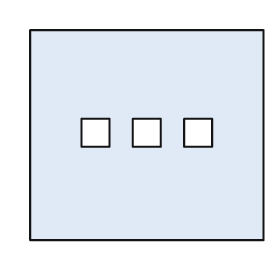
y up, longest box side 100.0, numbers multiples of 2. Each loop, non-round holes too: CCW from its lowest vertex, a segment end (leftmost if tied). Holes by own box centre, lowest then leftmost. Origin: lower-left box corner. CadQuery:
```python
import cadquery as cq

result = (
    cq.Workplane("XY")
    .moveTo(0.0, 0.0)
    .lineTo(100.0, 0.0)
    .lineTo(100.0, 90.0)
    .lineTo(0.0, 90.0)
    .close()
    .moveTo(22.0, 40.0)
    .lineTo(34.0, 40.0)
    .lineTo(34.0, 52.0)
    .lineTo(22.0, 52.0)
    .close()
    .moveTo(44.0, 40.0)
    .lineTo(56.0, 40.0)
    .lineTo(56.0, 52.0)
    .lineTo(44.0, 52.0)
    .close()
    .moveTo(66.0, 40.0)
    .lineTo(78.0, 40.0)
    .lineTo(78.0, 52.0)
    .lineTo(66.0, 52.0)
    .close()
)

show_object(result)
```